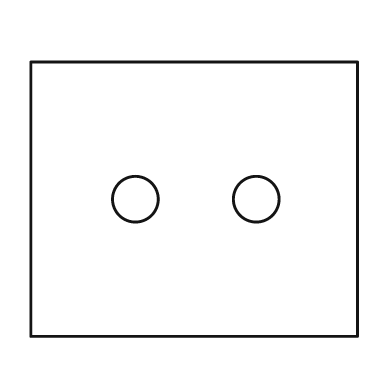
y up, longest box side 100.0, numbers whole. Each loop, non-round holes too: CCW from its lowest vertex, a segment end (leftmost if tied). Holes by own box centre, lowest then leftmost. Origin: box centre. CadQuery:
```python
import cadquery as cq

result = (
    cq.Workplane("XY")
    .moveTo(-50.0, -42.0)
    .lineTo(50.0, -42.0)
    .lineTo(50.0, 42.0)
    .lineTo(-50.0, 42.0)
    .close()
    .moveTo(-18.0, 0.0)
    .circle(7.0)
    .moveTo(19.0, 0.0)
    .circle(7.0)
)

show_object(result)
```